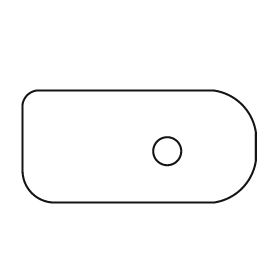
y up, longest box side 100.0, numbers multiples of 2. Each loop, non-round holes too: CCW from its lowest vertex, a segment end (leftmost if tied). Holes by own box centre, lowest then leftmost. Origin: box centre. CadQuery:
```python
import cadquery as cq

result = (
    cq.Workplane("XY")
    .moveTo(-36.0, -24.0)
    .lineTo(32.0, -24.0)
    .threePointArc((44.0, -18.0), (50.0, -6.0))
    .lineTo(50.0, 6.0)
    .threePointArc((44.0, 18.0), (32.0, 24.0))
    .lineTo(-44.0, 24.0)
    .threePointArc((-48.0, 22.0), (-50.0, 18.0))
    .lineTo(-50.0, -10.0)
    .threePointArc((-46.0, -20.0), (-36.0, -24.0))
    .close()
    .moveTo(12.0, -2.0)
    .circle(6.0)
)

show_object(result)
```